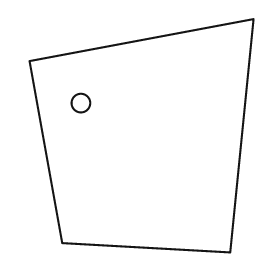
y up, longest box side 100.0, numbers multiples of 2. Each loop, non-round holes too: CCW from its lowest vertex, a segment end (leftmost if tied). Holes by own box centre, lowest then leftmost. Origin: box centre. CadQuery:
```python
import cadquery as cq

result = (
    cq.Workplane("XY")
    .moveTo(38.0, -50.0)
    .lineTo(48.0, 50.0)
    .lineTo(-48.0, 32.0)
    .lineTo(-34.0, -46.0)
    .close()
    .moveTo(-26.0, 14.0)
    .circle(4.0)
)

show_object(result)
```